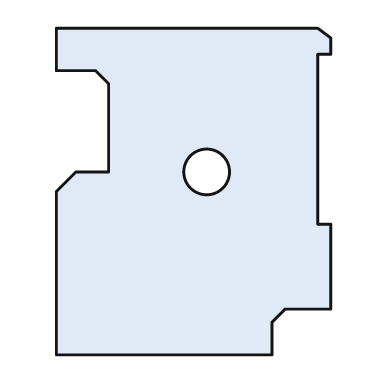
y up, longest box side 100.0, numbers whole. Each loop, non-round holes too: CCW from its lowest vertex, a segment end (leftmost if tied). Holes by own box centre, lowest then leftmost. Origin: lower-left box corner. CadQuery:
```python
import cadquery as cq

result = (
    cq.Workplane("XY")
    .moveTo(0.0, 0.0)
    .lineTo(66.0, 0.0)
    .lineTo(66.0, 10.0)
    .lineTo(70.0, 14.0)
    .lineTo(84.0, 14.0)
    .lineTo(84.0, 40.0)
    .lineTo(80.0, 40.0)
    .lineTo(80.0, 92.0)
    .lineTo(84.0, 92.0)
    .lineTo(84.0, 97.0)
    .lineTo(80.0, 100.0)
    .lineTo(0.0, 100.0)
    .lineTo(0.0, 87.0)
    .lineTo(12.0, 87.0)
    .lineTo(16.0, 83.0)
    .lineTo(16.0, 56.0)
    .lineTo(6.0, 56.0)
    .lineTo(0.0, 50.0)
    .close()
    .moveTo(46.0, 56.0)
    .circle(7.0)
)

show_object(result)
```